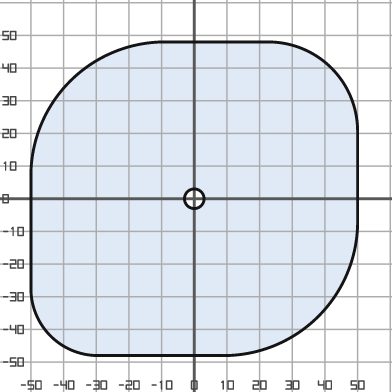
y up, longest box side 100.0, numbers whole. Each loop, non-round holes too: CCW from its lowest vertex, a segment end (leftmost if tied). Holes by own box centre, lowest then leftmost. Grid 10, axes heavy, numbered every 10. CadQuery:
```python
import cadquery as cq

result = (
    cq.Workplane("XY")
    .moveTo(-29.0, -48.0)
    .lineTo(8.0, -48.0)
    .threePointArc((38.0, -36.0), (50.0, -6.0))
    .lineTo(50.0, 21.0)
    .threePointArc((42.0, 40.0), (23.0, 48.0))
    .lineTo(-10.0, 48.0)
    .threePointArc((-38.0, 36.0), (-50.0, 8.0))
    .lineTo(-50.0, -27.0)
    .threePointArc((-44.0, -42.0), (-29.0, -48.0))
    .close()
    .moveTo(0.0, 0.0)
    .circle(3.0)
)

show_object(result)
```